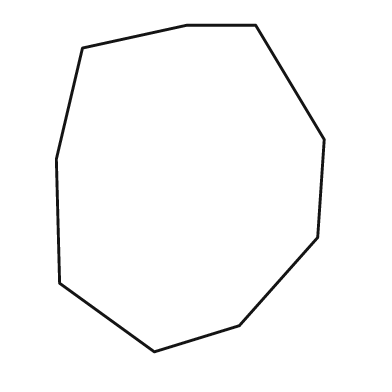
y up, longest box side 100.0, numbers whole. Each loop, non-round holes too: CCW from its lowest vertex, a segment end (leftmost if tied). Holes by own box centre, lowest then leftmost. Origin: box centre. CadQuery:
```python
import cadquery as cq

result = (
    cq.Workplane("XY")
    .moveTo(-11.0, -50.0)
    .lineTo(15.0, -42.0)
    .lineTo(39.0, -15.0)
    .lineTo(41.0, 15.0)
    .lineTo(20.0, 50.0)
    .lineTo(-1.0, 50.0)
    .lineTo(-33.0, 43.0)
    .lineTo(-41.0, 9.0)
    .lineTo(-40.0, -29.0)
    .close()
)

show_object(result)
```